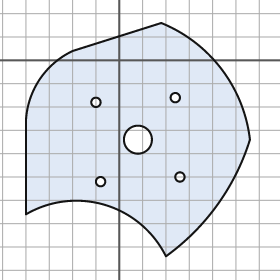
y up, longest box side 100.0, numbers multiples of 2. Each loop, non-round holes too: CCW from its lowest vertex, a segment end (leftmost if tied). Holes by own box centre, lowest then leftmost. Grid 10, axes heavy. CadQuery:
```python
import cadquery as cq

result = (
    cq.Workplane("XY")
    .moveTo(20.0, -84.0)
    .threePointArc((42.0, -62.0), (56.0, -34.0))
    .threePointArc((44.0, -4.0), (18.0, 16.0))
    .lineTo(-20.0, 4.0)
    .threePointArc((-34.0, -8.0), (-40.0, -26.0))
    .lineTo(-40.0, -66.0)
    .threePointArc((-6.0, -62.0), (20.0, -84.0))
    .close()
    .moveTo(-8.0, -52.0)
    .circle(2.0)
    .moveTo(26.0, -50.0)
    .circle(2.0)
    .moveTo(8.0, -34.0)
    .circle(6.0)
    .moveTo(-10.0, -18.0)
    .circle(2.0)
    .moveTo(24.0, -16.0)
    .circle(2.0)
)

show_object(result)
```